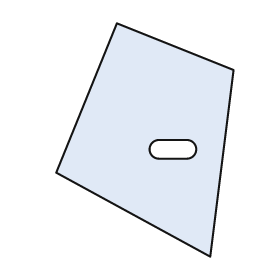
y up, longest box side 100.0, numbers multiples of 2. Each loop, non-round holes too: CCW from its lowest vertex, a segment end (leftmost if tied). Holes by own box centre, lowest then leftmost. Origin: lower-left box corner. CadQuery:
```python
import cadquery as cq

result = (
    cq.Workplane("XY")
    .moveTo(66.0, 0.0)
    .lineTo(76.0, 80.0)
    .lineTo(26.0, 100.0)
    .lineTo(0.0, 36.0)
    .close()
    .moveTo(44.0, 42.0)
    .lineTo(56.0, 42.0)
    .threePointArc((60.0, 46.0), (56.0, 50.0))
    .lineTo(44.0, 50.0)
    .threePointArc((40.0, 46.0), (44.0, 42.0))
    .close()
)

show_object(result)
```